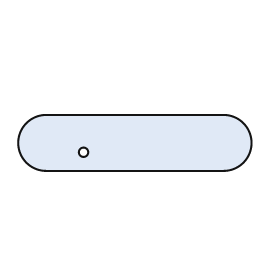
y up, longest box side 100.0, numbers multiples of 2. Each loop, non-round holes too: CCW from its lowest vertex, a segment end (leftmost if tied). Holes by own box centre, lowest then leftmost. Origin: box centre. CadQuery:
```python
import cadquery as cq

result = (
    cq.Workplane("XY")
    .moveTo(-38.0, -12.0)
    .lineTo(38.0, -12.0)
    .threePointArc((50.0, 0.0), (38.0, 12.0))
    .lineTo(-38.0, 12.0)
    .threePointArc((-50.0, 0.0), (-38.0, -12.0))
    .close()
    .moveTo(-22.0, -4.0)
    .circle(2.0)
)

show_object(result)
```